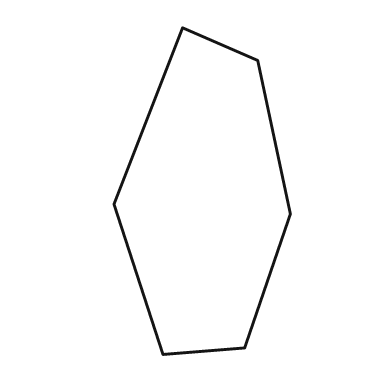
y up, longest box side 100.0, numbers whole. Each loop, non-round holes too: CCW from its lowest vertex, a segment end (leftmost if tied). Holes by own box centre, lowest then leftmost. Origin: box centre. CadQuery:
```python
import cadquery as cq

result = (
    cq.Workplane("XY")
    .moveTo(-12.0, -50.0)
    .lineTo(13.0, -48.0)
    .lineTo(27.0, -7.0)
    .lineTo(17.0, 40.0)
    .lineTo(-6.0, 50.0)
    .lineTo(-27.0, -4.0)
    .close()
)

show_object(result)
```